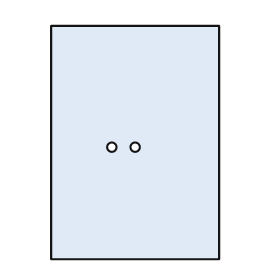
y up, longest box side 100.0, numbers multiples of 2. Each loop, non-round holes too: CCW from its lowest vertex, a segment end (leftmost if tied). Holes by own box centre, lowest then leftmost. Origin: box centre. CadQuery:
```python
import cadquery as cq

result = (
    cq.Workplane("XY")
    .moveTo(-36.0, -50.0)
    .lineTo(36.0, -50.0)
    .lineTo(36.0, 50.0)
    .lineTo(-36.0, 50.0)
    .close()
    .moveTo(-10.0, -2.0)
    .circle(2.0)
    .moveTo(0.0, -2.0)
    .circle(2.0)
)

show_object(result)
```